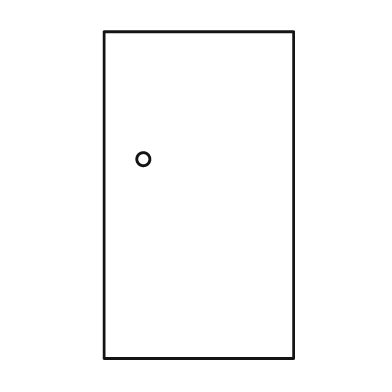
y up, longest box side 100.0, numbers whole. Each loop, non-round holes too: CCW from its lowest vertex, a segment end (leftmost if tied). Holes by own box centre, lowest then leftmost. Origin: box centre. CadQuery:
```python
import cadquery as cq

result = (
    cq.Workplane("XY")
    .moveTo(-29.0, -50.0)
    .lineTo(29.0, -50.0)
    .lineTo(29.0, 50.0)
    .lineTo(-29.0, 50.0)
    .close()
    .moveTo(-17.0, 11.0)
    .circle(2.0)
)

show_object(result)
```